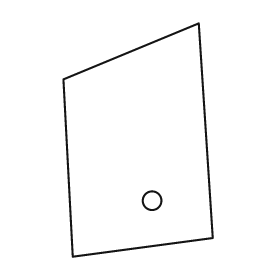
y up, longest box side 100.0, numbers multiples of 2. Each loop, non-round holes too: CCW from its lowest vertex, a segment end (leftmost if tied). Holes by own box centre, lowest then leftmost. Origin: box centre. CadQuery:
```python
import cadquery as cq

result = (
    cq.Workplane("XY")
    .moveTo(-28.0, -50.0)
    .lineTo(32.0, -42.0)
    .lineTo(26.0, 50.0)
    .lineTo(-32.0, 26.0)
    .close()
    .moveTo(6.0, -26.0)
    .circle(4.0)
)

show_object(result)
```